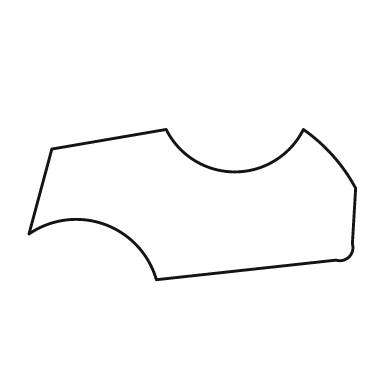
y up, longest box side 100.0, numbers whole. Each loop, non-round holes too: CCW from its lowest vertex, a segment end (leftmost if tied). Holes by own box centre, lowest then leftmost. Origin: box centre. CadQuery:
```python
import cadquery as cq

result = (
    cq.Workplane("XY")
    .moveTo(-11.0, -23.0)
    .lineTo(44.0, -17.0)
    .threePointArc((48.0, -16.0), (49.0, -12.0))
    .lineTo(50.0, 5.0)
    .threePointArc((43.0, 15.0), (34.0, 23.0))
    .threePointArc((13.0, 10.0), (-8.0, 23.0))
    .lineTo(-43.0, 17.0)
    .lineTo(-50.0, -9.0)
    .threePointArc((-27.0, -6.0), (-11.0, -23.0))
    .close()
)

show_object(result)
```